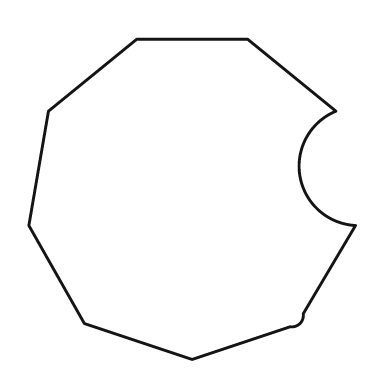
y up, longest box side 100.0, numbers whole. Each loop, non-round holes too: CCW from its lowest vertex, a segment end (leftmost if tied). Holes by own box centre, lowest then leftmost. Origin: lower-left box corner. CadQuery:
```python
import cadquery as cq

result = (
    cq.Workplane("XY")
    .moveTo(50.0, 0.0)
    .lineTo(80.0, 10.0)
    .threePointArc((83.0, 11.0), (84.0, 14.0))
    .lineTo(100.0, 41.0)
    .threePointArc((83.0, 56.0), (94.0, 76.0))
    .lineTo(67.0, 98.0)
    .lineTo(33.0, 98.0)
    .lineTo(6.0, 76.0)
    .lineTo(0.0, 41.0)
    .lineTo(17.0, 11.0)
    .close()
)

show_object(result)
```